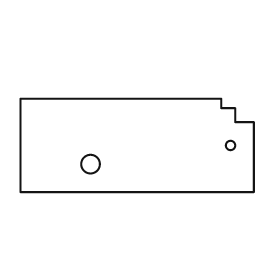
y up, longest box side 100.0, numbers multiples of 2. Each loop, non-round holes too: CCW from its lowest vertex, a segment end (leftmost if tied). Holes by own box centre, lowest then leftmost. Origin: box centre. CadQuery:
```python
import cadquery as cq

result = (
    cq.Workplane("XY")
    .moveTo(-50.0, -20.0)
    .lineTo(50.0, -20.0)
    .lineTo(50.0, 10.0)
    .lineTo(42.0, 10.0)
    .lineTo(42.0, 16.0)
    .lineTo(36.0, 16.0)
    .lineTo(36.0, 20.0)
    .lineTo(-50.0, 20.0)
    .close()
    .moveTo(-20.0, -8.0)
    .circle(4.0)
    .moveTo(40.0, 0.0)
    .circle(2.0)
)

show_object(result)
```